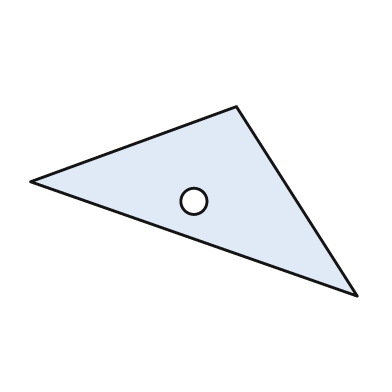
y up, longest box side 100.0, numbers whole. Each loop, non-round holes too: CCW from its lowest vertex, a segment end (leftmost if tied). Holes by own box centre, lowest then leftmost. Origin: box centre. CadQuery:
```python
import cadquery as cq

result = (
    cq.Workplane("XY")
    .moveTo(50.0, -29.0)
    .lineTo(13.0, 29.0)
    .lineTo(-50.0, 6.0)
    .close()
    .moveTo(0.0, 0.0)
    .circle(4.0)
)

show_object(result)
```